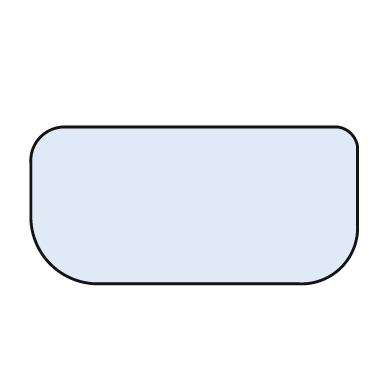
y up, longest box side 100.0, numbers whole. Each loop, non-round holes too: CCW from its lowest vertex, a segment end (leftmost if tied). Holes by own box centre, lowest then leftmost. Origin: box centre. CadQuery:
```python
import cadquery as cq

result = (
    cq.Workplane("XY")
    .moveTo(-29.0, -24.0)
    .lineTo(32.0, -24.0)
    .threePointArc((45.0, -19.0), (50.0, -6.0))
    .lineTo(50.0, 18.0)
    .threePointArc((48.0, 22.0), (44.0, 24.0))
    .lineTo(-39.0, 24.0)
    .threePointArc((-47.0, 21.0), (-50.0, 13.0))
    .lineTo(-50.0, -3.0)
    .threePointArc((-44.0, -18.0), (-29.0, -24.0))
    .close()
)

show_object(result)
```